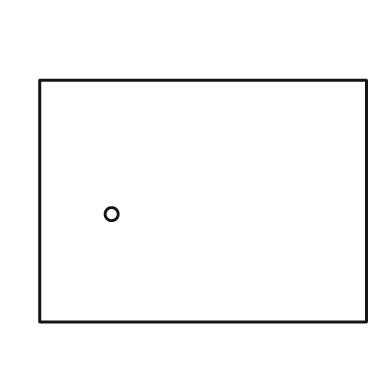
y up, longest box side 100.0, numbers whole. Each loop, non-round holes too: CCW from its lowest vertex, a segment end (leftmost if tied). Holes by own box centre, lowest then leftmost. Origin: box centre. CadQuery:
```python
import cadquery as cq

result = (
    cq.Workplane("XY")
    .moveTo(-50.0, -37.0)
    .lineTo(50.0, -37.0)
    .lineTo(50.0, 37.0)
    .lineTo(-50.0, 37.0)
    .close()
    .moveTo(-28.0, -4.0)
    .circle(2.0)
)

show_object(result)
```